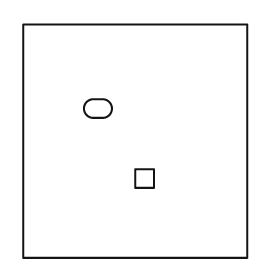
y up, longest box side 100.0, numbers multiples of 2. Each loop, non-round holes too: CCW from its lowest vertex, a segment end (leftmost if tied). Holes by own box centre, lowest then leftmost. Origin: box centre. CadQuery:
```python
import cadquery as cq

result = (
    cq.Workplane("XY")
    .moveTo(-48.0, -50.0)
    .lineTo(48.0, -50.0)
    .lineTo(48.0, 50.0)
    .lineTo(-48.0, 50.0)
    .close()
    .moveTo(0.0, -20.0)
    .lineTo(8.0, -20.0)
    .lineTo(8.0, -12.0)
    .lineTo(0.0, -12.0)
    .close()
    .moveTo(-18.0, 10.0)
    .lineTo(-14.0, 10.0)
    .threePointArc((-10.0, 14.0), (-14.0, 18.0))
    .lineTo(-18.0, 18.0)
    .threePointArc((-22.0, 14.0), (-18.0, 10.0))
    .close()
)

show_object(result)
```